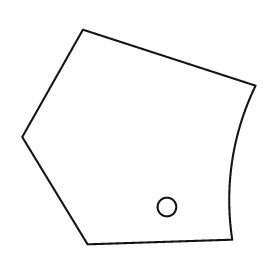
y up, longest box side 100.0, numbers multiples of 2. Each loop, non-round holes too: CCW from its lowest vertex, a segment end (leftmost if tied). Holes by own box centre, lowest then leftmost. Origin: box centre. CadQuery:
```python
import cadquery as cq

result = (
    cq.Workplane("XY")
    .moveTo(-22.0, -46.0)
    .lineTo(40.0, -44.0)
    .threePointArc((40.0, -10.0), (50.0, 22.0))
    .lineTo(-24.0, 46.0)
    .lineTo(-50.0, 0.0)
    .close()
    .moveTo(12.0, -30.0)
    .circle(4.0)
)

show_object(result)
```